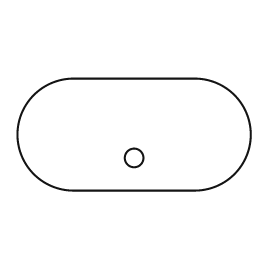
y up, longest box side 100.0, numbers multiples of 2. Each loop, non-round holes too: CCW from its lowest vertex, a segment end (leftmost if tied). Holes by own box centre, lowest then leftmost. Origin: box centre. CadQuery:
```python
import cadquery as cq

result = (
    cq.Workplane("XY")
    .moveTo(-26.0, -24.0)
    .lineTo(26.0, -24.0)
    .threePointArc((50.0, 0.0), (26.0, 24.0))
    .lineTo(-26.0, 24.0)
    .threePointArc((-50.0, 0.0), (-26.0, -24.0))
    .close()
    .moveTo(0.0, -10.0)
    .circle(4.0)
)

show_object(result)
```